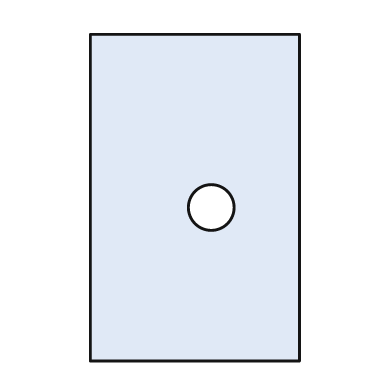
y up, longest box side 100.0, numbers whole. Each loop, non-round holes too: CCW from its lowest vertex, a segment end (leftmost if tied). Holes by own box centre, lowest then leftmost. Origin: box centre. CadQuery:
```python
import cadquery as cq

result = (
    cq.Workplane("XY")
    .moveTo(-32.0, -50.0)
    .lineTo(32.0, -50.0)
    .lineTo(32.0, 50.0)
    .lineTo(-32.0, 50.0)
    .close()
    .moveTo(5.0, -3.0)
    .circle(7.0)
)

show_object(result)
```